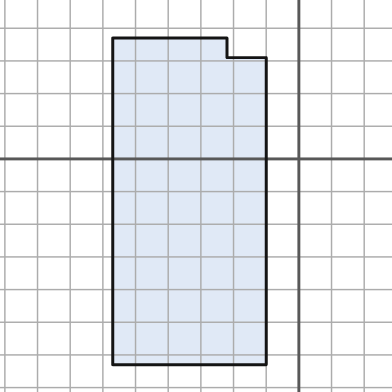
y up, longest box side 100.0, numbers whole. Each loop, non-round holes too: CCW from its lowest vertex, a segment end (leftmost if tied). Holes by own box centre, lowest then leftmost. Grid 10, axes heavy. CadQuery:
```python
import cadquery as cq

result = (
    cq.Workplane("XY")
    .moveTo(-57.0, -63.0)
    .lineTo(-10.0, -63.0)
    .lineTo(-10.0, 31.0)
    .lineTo(-22.0, 31.0)
    .lineTo(-22.0, 37.0)
    .lineTo(-57.0, 37.0)
    .close()
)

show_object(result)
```